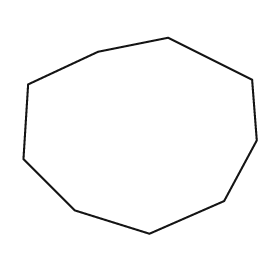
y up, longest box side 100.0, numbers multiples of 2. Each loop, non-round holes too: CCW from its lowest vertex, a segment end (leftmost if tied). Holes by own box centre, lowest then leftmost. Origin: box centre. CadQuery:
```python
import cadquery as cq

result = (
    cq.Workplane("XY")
    .moveTo(4.0, -42.0)
    .lineTo(36.0, -28.0)
    .lineTo(50.0, -2.0)
    .lineTo(48.0, 24.0)
    .lineTo(12.0, 42.0)
    .lineTo(-18.0, 36.0)
    .lineTo(-48.0, 22.0)
    .lineTo(-50.0, -10.0)
    .lineTo(-28.0, -32.0)
    .close()
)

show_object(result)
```